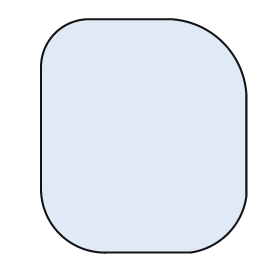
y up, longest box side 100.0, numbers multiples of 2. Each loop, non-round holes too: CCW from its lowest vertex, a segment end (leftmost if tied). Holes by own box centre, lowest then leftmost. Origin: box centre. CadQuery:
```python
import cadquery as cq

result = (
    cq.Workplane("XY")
    .moveTo(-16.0, -50.0)
    .lineTo(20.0, -50.0)
    .threePointArc((36.0, -42.0), (44.0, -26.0))
    .lineTo(44.0, 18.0)
    .threePointArc((34.0, 40.0), (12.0, 50.0))
    .lineTo(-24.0, 50.0)
    .threePointArc((-38.0, 44.0), (-44.0, 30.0))
    .lineTo(-44.0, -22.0)
    .threePointArc((-36.0, -42.0), (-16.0, -50.0))
    .close()
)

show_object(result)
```